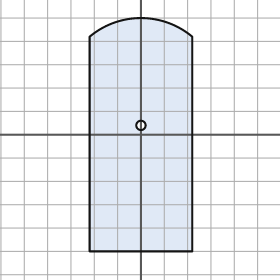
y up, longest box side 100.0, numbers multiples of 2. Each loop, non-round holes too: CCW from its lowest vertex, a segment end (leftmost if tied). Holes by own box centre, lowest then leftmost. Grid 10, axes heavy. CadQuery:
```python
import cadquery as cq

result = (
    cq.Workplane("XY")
    .moveTo(-22.0, -50.0)
    .lineTo(22.0, -50.0)
    .lineTo(22.0, 42.0)
    .threePointArc((0.0, 50.0), (-22.0, 42.0))
    .close()
    .moveTo(0.0, 4.0)
    .circle(2.0)
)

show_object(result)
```